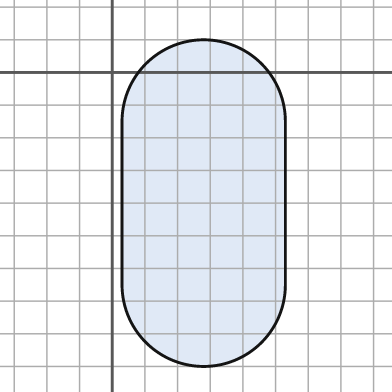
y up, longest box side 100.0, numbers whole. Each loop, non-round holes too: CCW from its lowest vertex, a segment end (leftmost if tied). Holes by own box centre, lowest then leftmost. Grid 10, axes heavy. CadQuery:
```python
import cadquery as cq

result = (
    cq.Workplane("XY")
    .moveTo(3.0, -65.0)
    .threePointArc((28.0, -90.0), (53.0, -65.0))
    .lineTo(53.0, -15.0)
    .threePointArc((28.0, 10.0), (3.0, -15.0))
    .close()
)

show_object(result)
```